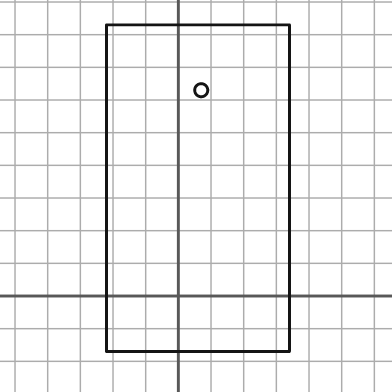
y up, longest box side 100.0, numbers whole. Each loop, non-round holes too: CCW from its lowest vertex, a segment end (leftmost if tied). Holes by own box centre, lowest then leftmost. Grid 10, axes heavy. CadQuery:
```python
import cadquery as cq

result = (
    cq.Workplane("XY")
    .moveTo(-22.0, -17.0)
    .lineTo(34.0, -17.0)
    .lineTo(34.0, 83.0)
    .lineTo(-22.0, 83.0)
    .close()
    .moveTo(7.0, 63.0)
    .circle(2.0)
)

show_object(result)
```